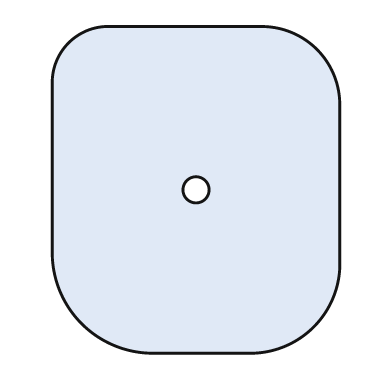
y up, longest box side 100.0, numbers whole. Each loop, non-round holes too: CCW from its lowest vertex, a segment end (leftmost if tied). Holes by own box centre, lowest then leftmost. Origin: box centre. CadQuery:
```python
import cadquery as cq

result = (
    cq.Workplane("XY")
    .moveTo(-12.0, -50.0)
    .lineTo(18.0, -50.0)
    .threePointArc((36.0, -42.0), (44.0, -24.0))
    .lineTo(44.0, 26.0)
    .threePointArc((37.0, 43.0), (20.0, 50.0))
    .lineTo(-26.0, 50.0)
    .threePointArc((-39.0, 45.0), (-44.0, 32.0))
    .lineTo(-44.0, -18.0)
    .threePointArc((-35.0, -41.0), (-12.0, -50.0))
    .close()
    .moveTo(0.0, 0.0)
    .circle(4.0)
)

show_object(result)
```